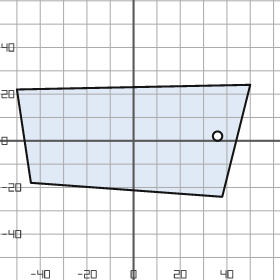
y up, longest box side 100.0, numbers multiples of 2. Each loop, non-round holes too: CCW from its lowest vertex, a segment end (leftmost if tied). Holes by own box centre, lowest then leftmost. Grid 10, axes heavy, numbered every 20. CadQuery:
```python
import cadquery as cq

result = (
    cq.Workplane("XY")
    .moveTo(38.0, -24.0)
    .lineTo(50.0, 24.0)
    .lineTo(-50.0, 22.0)
    .lineTo(-44.0, -18.0)
    .close()
    .moveTo(36.0, 2.0)
    .circle(2.0)
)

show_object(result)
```